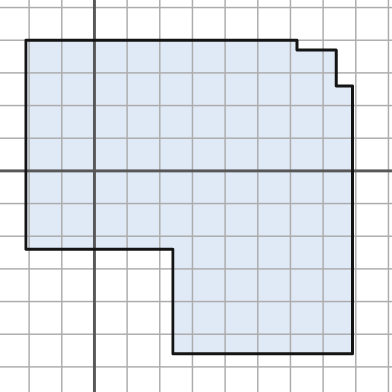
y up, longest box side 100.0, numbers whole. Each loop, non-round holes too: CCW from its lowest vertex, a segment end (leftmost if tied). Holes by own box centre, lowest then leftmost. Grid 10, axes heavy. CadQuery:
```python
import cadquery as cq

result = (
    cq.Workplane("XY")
    .moveTo(24.0, -56.0)
    .lineTo(79.0, -56.0)
    .lineTo(79.0, 26.0)
    .lineTo(74.0, 26.0)
    .lineTo(74.0, 37.0)
    .lineTo(62.0, 37.0)
    .lineTo(62.0, 40.0)
    .lineTo(-21.0, 40.0)
    .lineTo(-21.0, -24.0)
    .lineTo(24.0, -24.0)
    .close()
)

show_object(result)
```